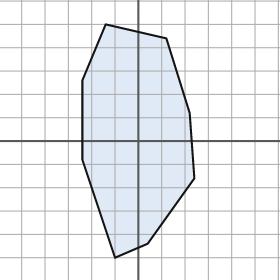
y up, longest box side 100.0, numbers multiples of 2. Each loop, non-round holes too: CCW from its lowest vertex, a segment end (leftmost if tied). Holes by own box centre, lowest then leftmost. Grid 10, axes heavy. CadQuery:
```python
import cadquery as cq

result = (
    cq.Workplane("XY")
    .moveTo(-10.0, -50.0)
    .lineTo(4.0, -44.0)
    .lineTo(24.0, -16.0)
    .lineTo(22.0, 12.0)
    .lineTo(12.0, 44.0)
    .lineTo(-14.0, 50.0)
    .lineTo(-24.0, 26.0)
    .lineTo(-24.0, -8.0)
    .close()
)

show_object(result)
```